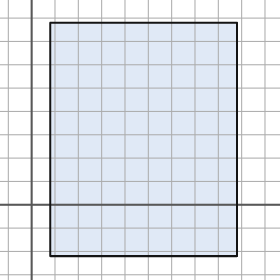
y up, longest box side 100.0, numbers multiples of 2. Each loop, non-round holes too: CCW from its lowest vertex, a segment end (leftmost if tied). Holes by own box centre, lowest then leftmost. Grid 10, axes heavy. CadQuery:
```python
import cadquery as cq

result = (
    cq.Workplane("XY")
    .moveTo(8.0, -22.0)
    .lineTo(88.0, -22.0)
    .lineTo(88.0, 78.0)
    .lineTo(8.0, 78.0)
    .close()
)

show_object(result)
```